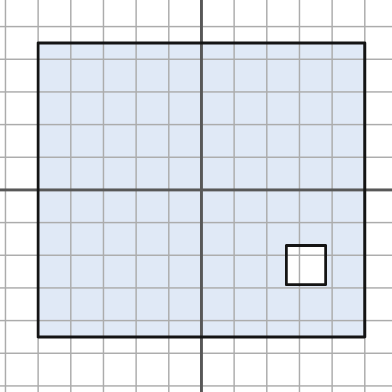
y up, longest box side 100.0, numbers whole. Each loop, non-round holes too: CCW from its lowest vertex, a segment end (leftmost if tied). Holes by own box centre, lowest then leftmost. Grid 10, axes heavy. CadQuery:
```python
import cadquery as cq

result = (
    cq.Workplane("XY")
    .moveTo(-50.0, -45.0)
    .lineTo(50.0, -45.0)
    .lineTo(50.0, 45.0)
    .lineTo(-50.0, 45.0)
    .close()
    .moveTo(26.0, -29.0)
    .lineTo(38.0, -29.0)
    .lineTo(38.0, -17.0)
    .lineTo(26.0, -17.0)
    .close()
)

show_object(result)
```